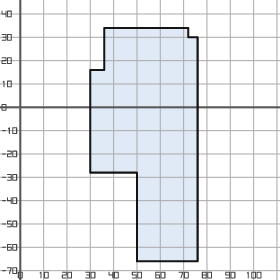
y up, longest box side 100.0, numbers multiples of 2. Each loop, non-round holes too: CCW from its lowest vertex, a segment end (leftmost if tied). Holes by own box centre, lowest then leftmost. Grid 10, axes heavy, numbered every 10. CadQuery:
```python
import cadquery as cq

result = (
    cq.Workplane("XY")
    .moveTo(50.0, -66.0)
    .lineTo(76.0, -66.0)
    .lineTo(76.0, 30.0)
    .lineTo(72.0, 30.0)
    .lineTo(72.0, 34.0)
    .lineTo(36.0, 34.0)
    .lineTo(36.0, 16.0)
    .lineTo(30.0, 16.0)
    .lineTo(30.0, -28.0)
    .lineTo(50.0, -28.0)
    .close()
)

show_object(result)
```